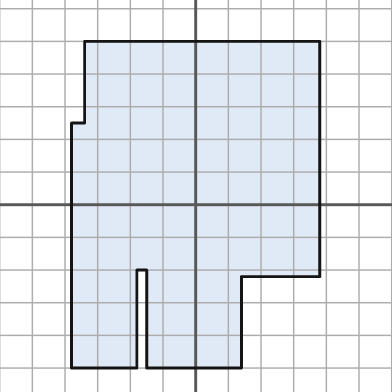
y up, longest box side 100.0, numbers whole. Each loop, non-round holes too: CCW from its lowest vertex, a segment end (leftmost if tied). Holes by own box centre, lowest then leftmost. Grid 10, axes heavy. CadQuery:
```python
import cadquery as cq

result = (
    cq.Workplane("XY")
    .moveTo(-38.0, -50.0)
    .lineTo(-18.0, -50.0)
    .lineTo(-18.0, -20.0)
    .lineTo(-15.0, -20.0)
    .lineTo(-15.0, -50.0)
    .lineTo(14.0, -50.0)
    .lineTo(14.0, -22.0)
    .lineTo(38.0, -22.0)
    .lineTo(38.0, 50.0)
    .lineTo(-34.0, 50.0)
    .lineTo(-34.0, 25.0)
    .lineTo(-38.0, 25.0)
    .close()
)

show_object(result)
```